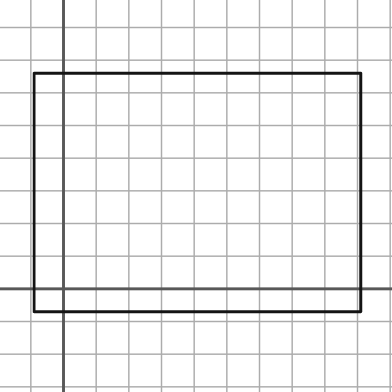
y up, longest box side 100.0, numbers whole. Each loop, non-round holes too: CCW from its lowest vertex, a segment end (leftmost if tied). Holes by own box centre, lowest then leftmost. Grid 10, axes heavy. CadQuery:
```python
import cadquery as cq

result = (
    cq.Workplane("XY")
    .moveTo(-9.0, -7.0)
    .lineTo(91.0, -7.0)
    .lineTo(91.0, 66.0)
    .lineTo(-9.0, 66.0)
    .close()
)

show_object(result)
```